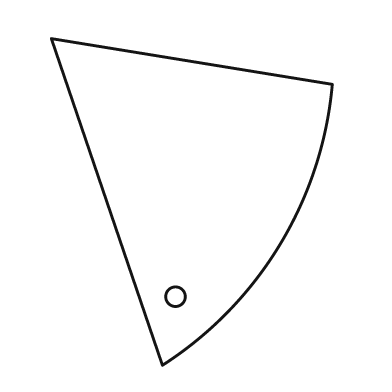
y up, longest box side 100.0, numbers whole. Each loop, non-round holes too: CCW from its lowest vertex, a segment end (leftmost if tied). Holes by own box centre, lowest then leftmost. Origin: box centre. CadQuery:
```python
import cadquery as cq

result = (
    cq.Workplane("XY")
    .moveTo(-9.0, -50.0)
    .threePointArc((27.0, -13.0), (43.0, 36.0))
    .lineTo(-43.0, 50.0)
    .close()
    .moveTo(-5.0, -29.0)
    .circle(3.0)
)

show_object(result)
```